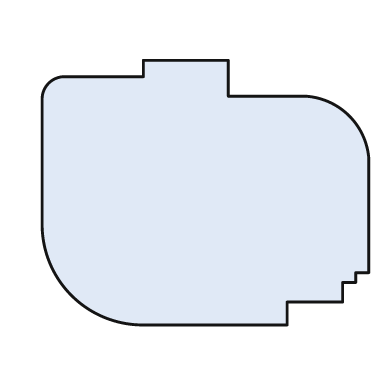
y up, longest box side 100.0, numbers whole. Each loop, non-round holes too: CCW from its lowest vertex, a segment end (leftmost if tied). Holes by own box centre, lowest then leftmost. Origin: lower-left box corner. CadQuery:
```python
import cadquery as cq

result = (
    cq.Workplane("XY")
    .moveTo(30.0, 0.0)
    .lineTo(75.0, 0.0)
    .lineTo(75.0, 7.0)
    .lineTo(92.0, 7.0)
    .lineTo(92.0, 13.0)
    .lineTo(96.0, 13.0)
    .lineTo(96.0, 16.0)
    .lineTo(100.0, 16.0)
    .lineTo(100.0, 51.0)
    .threePointArc((94.0, 64.0), (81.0, 70.0))
    .lineTo(57.0, 70.0)
    .lineTo(57.0, 81.0)
    .lineTo(31.0, 81.0)
    .lineTo(31.0, 76.0)
    .lineTo(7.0, 76.0)
    .threePointArc((2.0, 74.0), (0.0, 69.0))
    .lineTo(0.0, 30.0)
    .threePointArc((9.0, 9.0), (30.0, 0.0))
    .close()
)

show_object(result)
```